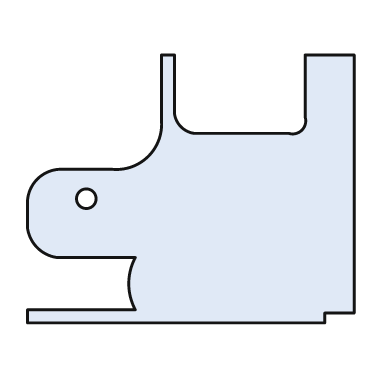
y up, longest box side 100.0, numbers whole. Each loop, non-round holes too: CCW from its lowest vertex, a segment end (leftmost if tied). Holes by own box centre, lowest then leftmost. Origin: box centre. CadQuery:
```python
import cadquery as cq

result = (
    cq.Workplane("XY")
    .moveTo(-50.0, -41.0)
    .lineTo(41.0, -41.0)
    .lineTo(41.0, -38.0)
    .lineTo(50.0, -38.0)
    .lineTo(50.0, 41.0)
    .lineTo(35.0, 41.0)
    .lineTo(35.0, 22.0)
    .threePointArc((34.0, 18.0), (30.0, 17.0))
    .lineTo(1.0, 17.0)
    .threePointArc((-3.0, 19.0), (-5.0, 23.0))
    .lineTo(-5.0, 41.0)
    .lineTo(-9.0, 41.0)
    .lineTo(-9.0, 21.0)
    .threePointArc((-13.0, 10.0), (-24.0, 6.0))
    .lineTo(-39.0, 6.0)
    .threePointArc((-47.0, 3.0), (-50.0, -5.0))
    .lineTo(-50.0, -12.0)
    .threePointArc((-47.0, -18.0), (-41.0, -21.0))
    .lineTo(-17.0, -21.0)
    .threePointArc((-19.0, -29.0), (-17.0, -37.0))
    .lineTo(-50.0, -37.0)
    .close()
    .moveTo(-32.0, -3.0)
    .circle(3.0)
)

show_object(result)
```